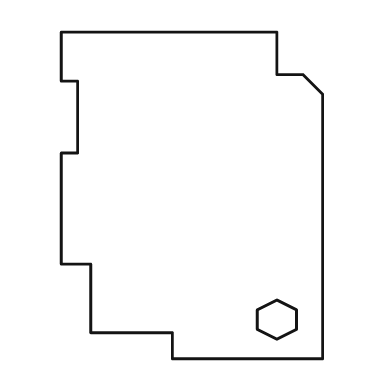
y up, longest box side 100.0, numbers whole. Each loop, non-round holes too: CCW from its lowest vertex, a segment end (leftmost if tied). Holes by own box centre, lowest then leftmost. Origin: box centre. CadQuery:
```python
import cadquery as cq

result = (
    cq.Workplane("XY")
    .moveTo(-6.0, -50.0)
    .lineTo(40.0, -50.0)
    .lineTo(40.0, 31.0)
    .lineTo(34.0, 37.0)
    .lineTo(26.0, 37.0)
    .lineTo(26.0, 50.0)
    .lineTo(-40.0, 50.0)
    .lineTo(-40.0, 35.0)
    .lineTo(-35.0, 35.0)
    .lineTo(-35.0, 13.0)
    .lineTo(-40.0, 13.0)
    .lineTo(-40.0, -21.0)
    .lineTo(-31.0, -21.0)
    .lineTo(-31.0, -42.0)
    .lineTo(-6.0, -42.0)
    .close()
    .moveTo(26.0, -44.0)
    .lineTo(32.0, -41.0)
    .lineTo(32.0, -35.0)
    .lineTo(26.0, -32.0)
    .lineTo(20.0, -35.0)
    .lineTo(20.0, -41.0)
    .close()
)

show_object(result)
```